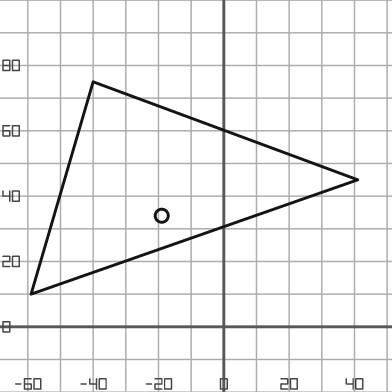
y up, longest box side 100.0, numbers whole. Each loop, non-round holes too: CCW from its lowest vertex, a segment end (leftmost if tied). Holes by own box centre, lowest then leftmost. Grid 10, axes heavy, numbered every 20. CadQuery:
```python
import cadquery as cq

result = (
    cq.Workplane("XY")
    .moveTo(-59.0, 10.0)
    .lineTo(41.0, 45.0)
    .lineTo(-40.0, 75.0)
    .close()
    .moveTo(-19.0, 34.0)
    .circle(2.0)
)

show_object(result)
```